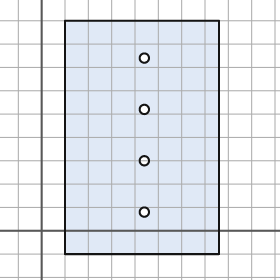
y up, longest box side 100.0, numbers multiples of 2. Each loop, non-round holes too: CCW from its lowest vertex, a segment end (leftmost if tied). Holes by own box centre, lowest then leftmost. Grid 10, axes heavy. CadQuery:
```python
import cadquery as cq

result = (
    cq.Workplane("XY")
    .moveTo(10.0, -10.0)
    .lineTo(76.0, -10.0)
    .lineTo(76.0, 90.0)
    .lineTo(10.0, 90.0)
    .close()
    .moveTo(44.0, 8.0)
    .circle(2.0)
    .moveTo(44.0, 30.0)
    .circle(2.0)
    .moveTo(44.0, 52.0)
    .circle(2.0)
    .moveTo(44.0, 74.0)
    .circle(2.0)
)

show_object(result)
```